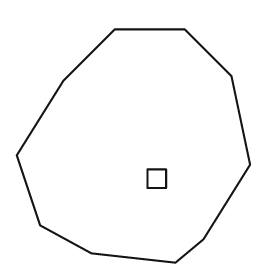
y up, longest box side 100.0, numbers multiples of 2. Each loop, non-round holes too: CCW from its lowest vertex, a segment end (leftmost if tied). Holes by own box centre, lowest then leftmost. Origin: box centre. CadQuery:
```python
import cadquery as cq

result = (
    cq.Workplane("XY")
    .moveTo(18.0, -50.0)
    .lineTo(30.0, -40.0)
    .lineTo(50.0, -8.0)
    .lineTo(42.0, 30.0)
    .lineTo(22.0, 50.0)
    .lineTo(-8.0, 50.0)
    .lineTo(-30.0, 28.0)
    .lineTo(-50.0, -4.0)
    .lineTo(-40.0, -34.0)
    .lineTo(-18.0, -46.0)
    .close()
    .moveTo(6.0, -18.0)
    .lineTo(14.0, -18.0)
    .lineTo(14.0, -10.0)
    .lineTo(6.0, -10.0)
    .close()
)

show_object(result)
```